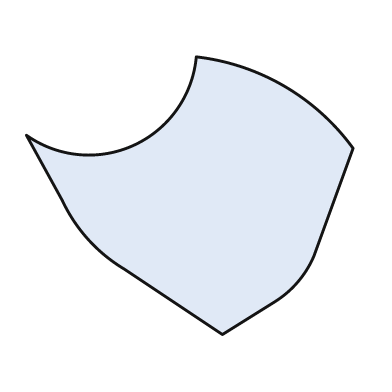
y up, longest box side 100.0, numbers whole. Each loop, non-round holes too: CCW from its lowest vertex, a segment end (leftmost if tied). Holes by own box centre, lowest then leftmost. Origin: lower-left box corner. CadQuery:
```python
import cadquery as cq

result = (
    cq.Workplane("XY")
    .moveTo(60.0, 0.0)
    .lineTo(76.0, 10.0)
    .threePointArc((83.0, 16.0), (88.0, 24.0))
    .lineTo(100.0, 57.0)
    .threePointArc((79.0, 76.0), (52.0, 85.0))
    .threePointArc((33.0, 58.0), (0.0, 61.0))
    .lineTo(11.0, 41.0)
    .threePointArc((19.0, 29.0), (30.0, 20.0))
    .close()
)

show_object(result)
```